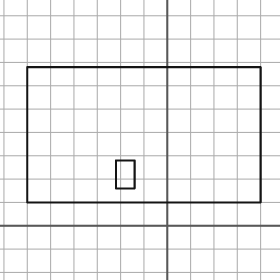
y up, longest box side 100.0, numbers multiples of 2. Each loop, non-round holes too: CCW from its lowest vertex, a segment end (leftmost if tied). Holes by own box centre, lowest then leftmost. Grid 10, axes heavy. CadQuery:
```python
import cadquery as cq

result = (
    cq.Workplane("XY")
    .moveTo(-60.0, 10.0)
    .lineTo(40.0, 10.0)
    .lineTo(40.0, 68.0)
    .lineTo(-60.0, 68.0)
    .close()
    .moveTo(-22.0, 16.0)
    .lineTo(-14.0, 16.0)
    .lineTo(-14.0, 28.0)
    .lineTo(-22.0, 28.0)
    .close()
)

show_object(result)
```